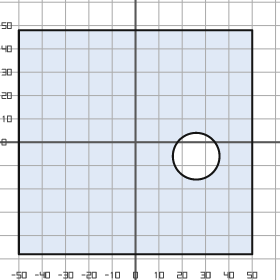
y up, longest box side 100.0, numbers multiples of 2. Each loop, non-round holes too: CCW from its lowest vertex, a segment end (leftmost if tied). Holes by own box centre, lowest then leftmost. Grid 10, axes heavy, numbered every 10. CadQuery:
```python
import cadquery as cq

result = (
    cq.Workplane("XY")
    .moveTo(-50.0, -48.0)
    .lineTo(50.0, -48.0)
    .lineTo(50.0, 48.0)
    .lineTo(-50.0, 48.0)
    .close()
    .moveTo(26.0, -6.0)
    .circle(10.0)
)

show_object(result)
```